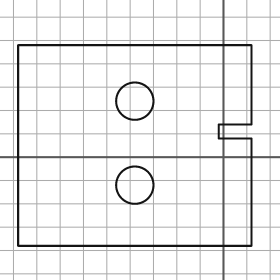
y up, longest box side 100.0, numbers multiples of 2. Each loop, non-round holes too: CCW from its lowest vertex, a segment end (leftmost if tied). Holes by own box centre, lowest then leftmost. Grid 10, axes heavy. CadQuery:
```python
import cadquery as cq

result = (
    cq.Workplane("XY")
    .moveTo(-88.0, -38.0)
    .lineTo(12.0, -38.0)
    .lineTo(12.0, 8.0)
    .lineTo(-2.0, 8.0)
    .lineTo(-2.0, 14.0)
    .lineTo(12.0, 14.0)
    .lineTo(12.0, 48.0)
    .lineTo(-88.0, 48.0)
    .close()
    .moveTo(-38.0, -12.0)
    .circle(8.0)
    .moveTo(-38.0, 24.0)
    .circle(8.0)
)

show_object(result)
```